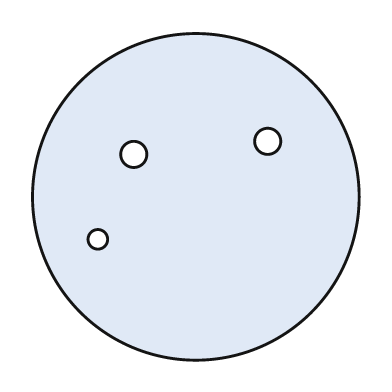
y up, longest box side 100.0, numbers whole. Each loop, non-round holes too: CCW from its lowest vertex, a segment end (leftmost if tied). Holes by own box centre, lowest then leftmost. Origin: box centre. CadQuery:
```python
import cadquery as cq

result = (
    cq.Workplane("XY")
    .moveTo(0.0, 0.0)
    .circle(50.0)
    .moveTo(-30.0, -13.0)
    .circle(3.0)
    .moveTo(-19.0, 13.0)
    .circle(4.0)
    .moveTo(22.0, 17.0)
    .circle(4.0)
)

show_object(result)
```